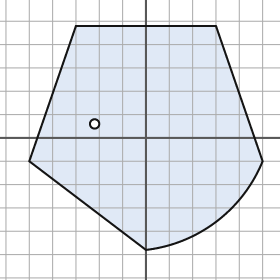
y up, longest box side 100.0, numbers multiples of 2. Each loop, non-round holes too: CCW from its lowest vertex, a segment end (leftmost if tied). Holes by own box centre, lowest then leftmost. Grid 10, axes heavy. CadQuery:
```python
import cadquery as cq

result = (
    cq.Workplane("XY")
    .moveTo(0.0, -48.0)
    .threePointArc((30.0, -36.0), (50.0, -10.0))
    .lineTo(30.0, 48.0)
    .lineTo(-30.0, 48.0)
    .lineTo(-50.0, -10.0)
    .close()
    .moveTo(-22.0, 6.0)
    .circle(2.0)
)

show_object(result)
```